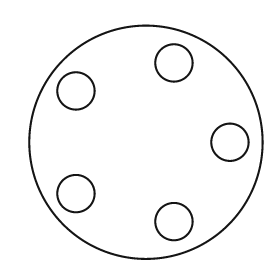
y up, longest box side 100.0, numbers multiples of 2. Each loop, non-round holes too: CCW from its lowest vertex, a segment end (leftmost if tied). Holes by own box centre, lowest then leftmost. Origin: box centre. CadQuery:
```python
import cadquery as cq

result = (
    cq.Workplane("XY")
    .moveTo(0.0, 0.0)
    .circle(50.0)
    .moveTo(12.0, -34.0)
    .circle(8.0)
    .moveTo(-30.0, -22.0)
    .circle(8.0)
    .moveTo(36.0, 0.0)
    .circle(8.0)
    .moveTo(-30.0, 22.0)
    .circle(8.0)
    .moveTo(12.0, 34.0)
    .circle(8.0)
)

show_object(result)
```